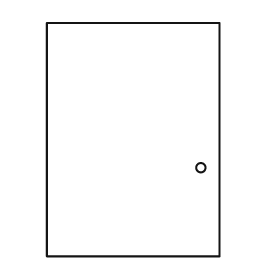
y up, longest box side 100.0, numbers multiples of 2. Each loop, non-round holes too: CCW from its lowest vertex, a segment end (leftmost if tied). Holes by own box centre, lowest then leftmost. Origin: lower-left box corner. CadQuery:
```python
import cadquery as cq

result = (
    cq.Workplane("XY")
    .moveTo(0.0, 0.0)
    .lineTo(74.0, 0.0)
    .lineTo(74.0, 100.0)
    .lineTo(0.0, 100.0)
    .close()
    .moveTo(66.0, 38.0)
    .circle(2.0)
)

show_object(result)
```